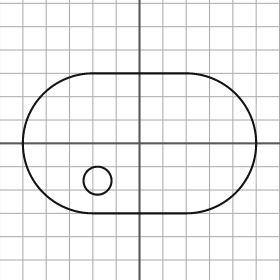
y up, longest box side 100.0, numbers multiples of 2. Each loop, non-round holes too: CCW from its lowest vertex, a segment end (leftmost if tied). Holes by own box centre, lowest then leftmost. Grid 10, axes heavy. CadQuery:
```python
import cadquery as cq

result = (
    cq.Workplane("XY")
    .moveTo(-20.0, -30.0)
    .lineTo(20.0, -30.0)
    .threePointArc((50.0, 0.0), (20.0, 30.0))
    .lineTo(-20.0, 30.0)
    .threePointArc((-50.0, 0.0), (-20.0, -30.0))
    .close()
    .moveTo(-18.0, -16.0)
    .circle(6.0)
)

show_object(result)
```